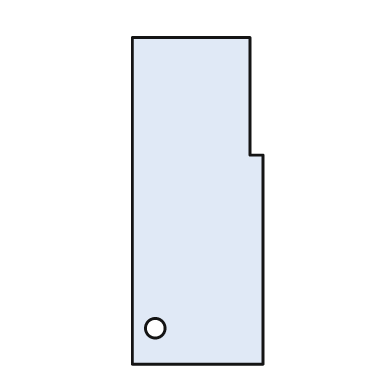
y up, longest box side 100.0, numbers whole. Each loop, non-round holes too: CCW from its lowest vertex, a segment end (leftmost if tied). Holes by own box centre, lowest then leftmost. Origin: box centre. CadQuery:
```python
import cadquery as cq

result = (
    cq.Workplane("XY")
    .moveTo(-20.0, -50.0)
    .lineTo(20.0, -50.0)
    .lineTo(20.0, 14.0)
    .lineTo(16.0, 14.0)
    .lineTo(16.0, 50.0)
    .lineTo(-20.0, 50.0)
    .close()
    .moveTo(-13.0, -39.0)
    .circle(3.0)
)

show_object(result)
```